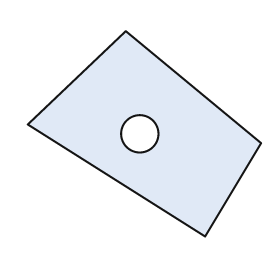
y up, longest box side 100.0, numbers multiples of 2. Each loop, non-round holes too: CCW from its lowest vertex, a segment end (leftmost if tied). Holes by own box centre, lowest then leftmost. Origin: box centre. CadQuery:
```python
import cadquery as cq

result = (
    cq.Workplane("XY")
    .moveTo(26.0, -44.0)
    .lineTo(50.0, -4.0)
    .lineTo(-8.0, 44.0)
    .lineTo(-50.0, 4.0)
    .close()
    .moveTo(-2.0, 0.0)
    .circle(8.0)
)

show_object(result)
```